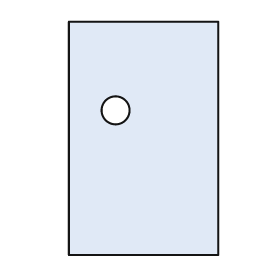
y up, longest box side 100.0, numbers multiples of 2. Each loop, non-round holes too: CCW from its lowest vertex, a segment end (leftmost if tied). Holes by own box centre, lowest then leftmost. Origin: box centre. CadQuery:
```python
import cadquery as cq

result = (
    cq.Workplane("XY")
    .moveTo(-32.0, -50.0)
    .lineTo(32.0, -50.0)
    .lineTo(32.0, 50.0)
    .lineTo(-32.0, 50.0)
    .close()
    .moveTo(-12.0, 12.0)
    .circle(6.0)
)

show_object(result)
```